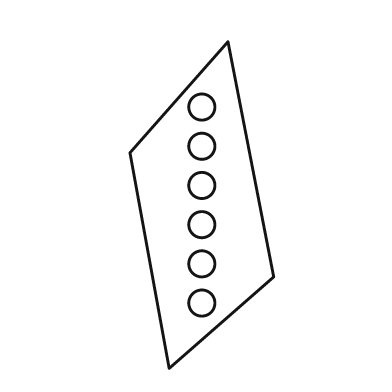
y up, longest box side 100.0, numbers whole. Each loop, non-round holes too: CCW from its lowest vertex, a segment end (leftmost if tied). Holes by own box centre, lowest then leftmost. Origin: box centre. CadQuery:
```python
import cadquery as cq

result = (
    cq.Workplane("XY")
    .moveTo(-10.0, -50.0)
    .lineTo(22.0, -22.0)
    .lineTo(8.0, 50.0)
    .lineTo(-22.0, 16.0)
    .close()
    .moveTo(0.0, -30.0)
    .circle(4.0)
    .moveTo(0.0, -18.0)
    .circle(4.0)
    .moveTo(0.0, -6.0)
    .circle(4.0)
    .moveTo(0.0, 6.0)
    .circle(4.0)
    .moveTo(0.0, 18.0)
    .circle(4.0)
    .moveTo(0.0, 30.0)
    .circle(4.0)
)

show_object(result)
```